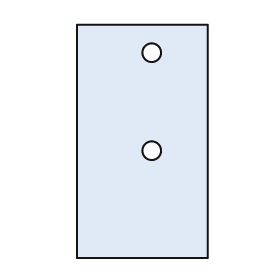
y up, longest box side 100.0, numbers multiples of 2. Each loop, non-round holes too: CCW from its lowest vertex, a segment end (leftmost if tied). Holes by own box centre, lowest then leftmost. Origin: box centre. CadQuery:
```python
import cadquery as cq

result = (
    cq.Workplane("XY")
    .moveTo(-28.0, -50.0)
    .lineTo(28.0, -50.0)
    .lineTo(28.0, 50.0)
    .lineTo(-28.0, 50.0)
    .close()
    .moveTo(4.0, -4.0)
    .circle(4.0)
    .moveTo(4.0, 38.0)
    .circle(4.0)
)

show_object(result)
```